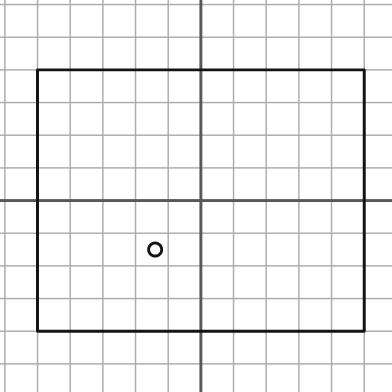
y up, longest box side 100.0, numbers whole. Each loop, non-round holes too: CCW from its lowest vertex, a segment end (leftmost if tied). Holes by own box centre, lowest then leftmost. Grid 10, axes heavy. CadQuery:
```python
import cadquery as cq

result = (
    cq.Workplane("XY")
    .moveTo(-50.0, -40.0)
    .lineTo(50.0, -40.0)
    .lineTo(50.0, 40.0)
    .lineTo(-50.0, 40.0)
    .close()
    .moveTo(-14.0, -15.0)
    .circle(2.0)
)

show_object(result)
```